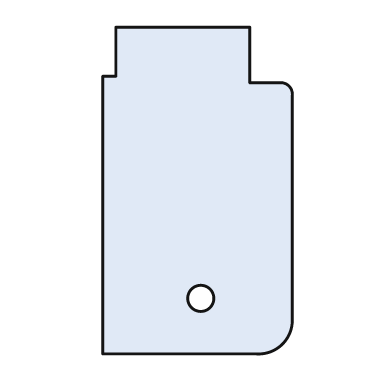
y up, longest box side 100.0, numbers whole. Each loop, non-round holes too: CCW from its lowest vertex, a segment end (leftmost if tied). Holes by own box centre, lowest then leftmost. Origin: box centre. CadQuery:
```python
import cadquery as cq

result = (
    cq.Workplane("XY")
    .moveTo(-29.0, -50.0)
    .lineTo(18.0, -50.0)
    .threePointArc((26.0, -47.0), (29.0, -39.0))
    .lineTo(29.0, 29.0)
    .threePointArc((28.0, 32.0), (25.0, 33.0))
    .lineTo(16.0, 33.0)
    .lineTo(16.0, 50.0)
    .lineTo(-25.0, 50.0)
    .lineTo(-25.0, 35.0)
    .lineTo(-29.0, 35.0)
    .close()
    .moveTo(1.0, -33.0)
    .circle(4.0)
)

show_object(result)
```